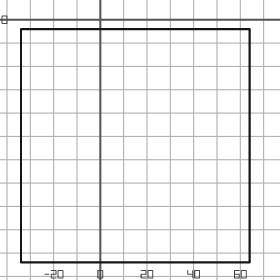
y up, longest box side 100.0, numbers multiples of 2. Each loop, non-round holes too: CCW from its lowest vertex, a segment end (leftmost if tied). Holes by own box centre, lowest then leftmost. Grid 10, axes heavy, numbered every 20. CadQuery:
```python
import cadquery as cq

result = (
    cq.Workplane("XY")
    .moveTo(-34.0, -104.0)
    .lineTo(64.0, -104.0)
    .lineTo(64.0, -4.0)
    .lineTo(-34.0, -4.0)
    .close()
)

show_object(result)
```